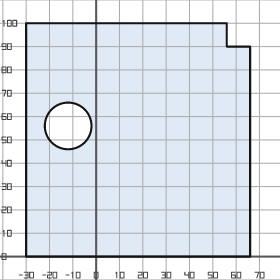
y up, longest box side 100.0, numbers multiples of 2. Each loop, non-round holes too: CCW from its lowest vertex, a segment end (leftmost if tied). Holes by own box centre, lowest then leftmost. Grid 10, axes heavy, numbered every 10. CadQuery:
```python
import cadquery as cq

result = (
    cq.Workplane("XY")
    .moveTo(-30.0, 0.0)
    .lineTo(66.0, 0.0)
    .lineTo(66.0, 90.0)
    .lineTo(56.0, 90.0)
    .lineTo(56.0, 100.0)
    .lineTo(-30.0, 100.0)
    .close()
    .moveTo(-12.0, 56.0)
    .circle(10.0)
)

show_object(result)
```